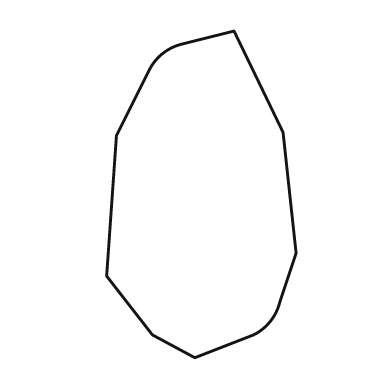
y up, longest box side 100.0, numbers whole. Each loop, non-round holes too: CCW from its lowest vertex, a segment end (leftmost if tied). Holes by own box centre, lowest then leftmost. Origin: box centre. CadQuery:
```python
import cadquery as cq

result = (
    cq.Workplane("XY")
    .moveTo(-2.0, -50.0)
    .lineTo(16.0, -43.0)
    .threePointArc((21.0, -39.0), (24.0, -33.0))
    .lineTo(29.0, -18.0)
    .lineTo(25.0, 19.0)
    .lineTo(10.0, 50.0)
    .lineTo(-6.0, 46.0)
    .threePointArc((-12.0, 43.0), (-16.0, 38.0))
    .lineTo(-26.0, 18.0)
    .lineTo(-29.0, -25.0)
    .lineTo(-15.0, -43.0)
    .close()
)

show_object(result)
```